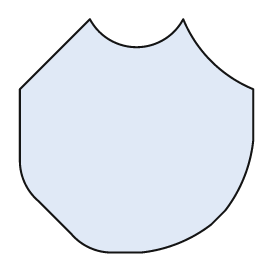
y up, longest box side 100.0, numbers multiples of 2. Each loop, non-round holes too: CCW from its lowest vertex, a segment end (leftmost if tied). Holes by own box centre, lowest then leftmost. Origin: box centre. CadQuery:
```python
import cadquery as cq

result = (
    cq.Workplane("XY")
    .moveTo(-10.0, -50.0)
    .lineTo(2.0, -50.0)
    .threePointArc((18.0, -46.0), (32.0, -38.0))
    .lineTo(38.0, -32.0)
    .threePointArc((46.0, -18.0), (50.0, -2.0))
    .lineTo(50.0, 20.0)
    .threePointArc((32.0, 32.0), (20.0, 50.0))
    .threePointArc((0.0, 38.0), (-20.0, 50.0))
    .lineTo(-50.0, 20.0)
    .lineTo(-50.0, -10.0)
    .threePointArc((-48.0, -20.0), (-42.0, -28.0))
    .lineTo(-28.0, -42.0)
    .threePointArc((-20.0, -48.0), (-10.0, -50.0))
    .close()
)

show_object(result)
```